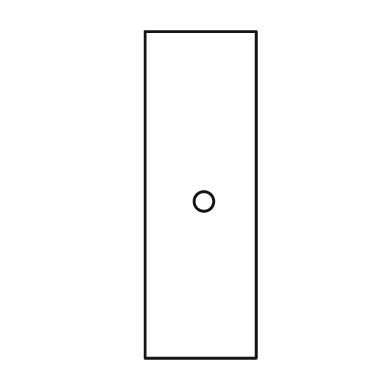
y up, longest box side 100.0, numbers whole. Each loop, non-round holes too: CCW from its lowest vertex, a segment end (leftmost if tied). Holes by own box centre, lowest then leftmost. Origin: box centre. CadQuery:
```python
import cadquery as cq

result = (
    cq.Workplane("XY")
    .moveTo(-17.0, -50.0)
    .lineTo(17.0, -50.0)
    .lineTo(17.0, 50.0)
    .lineTo(-17.0, 50.0)
    .close()
    .moveTo(1.0, -2.0)
    .circle(3.0)
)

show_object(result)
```